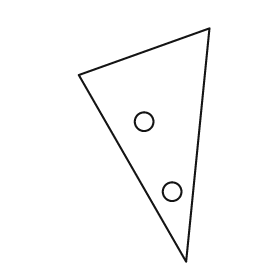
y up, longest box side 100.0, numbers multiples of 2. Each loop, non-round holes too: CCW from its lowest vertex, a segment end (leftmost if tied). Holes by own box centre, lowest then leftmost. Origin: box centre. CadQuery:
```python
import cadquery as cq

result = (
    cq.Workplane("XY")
    .moveTo(18.0, -50.0)
    .lineTo(28.0, 50.0)
    .lineTo(-28.0, 30.0)
    .close()
    .moveTo(12.0, -20.0)
    .circle(4.0)
    .moveTo(0.0, 10.0)
    .circle(4.0)
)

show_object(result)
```